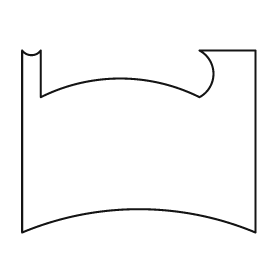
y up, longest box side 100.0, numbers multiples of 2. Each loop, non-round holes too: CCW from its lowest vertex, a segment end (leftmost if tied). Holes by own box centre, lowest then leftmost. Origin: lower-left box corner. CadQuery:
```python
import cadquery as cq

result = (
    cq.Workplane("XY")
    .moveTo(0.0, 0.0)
    .threePointArc((50.0, 10.0), (100.0, 0.0))
    .lineTo(100.0, 78.0)
    .lineTo(76.0, 78.0)
    .threePointArc((82.0, 68.0), (76.0, 58.0))
    .threePointArc((42.0, 66.0), (8.0, 58.0))
    .lineTo(8.0, 78.0)
    .threePointArc((4.0, 76.0), (0.0, 78.0))
    .close()
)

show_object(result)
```